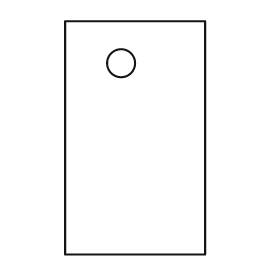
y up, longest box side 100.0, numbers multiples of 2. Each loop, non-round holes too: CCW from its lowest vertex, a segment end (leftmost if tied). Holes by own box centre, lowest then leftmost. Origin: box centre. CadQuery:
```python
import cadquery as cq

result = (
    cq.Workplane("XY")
    .moveTo(-30.0, -50.0)
    .lineTo(30.0, -50.0)
    .lineTo(30.0, 50.0)
    .lineTo(-30.0, 50.0)
    .close()
    .moveTo(-6.0, 32.0)
    .circle(6.0)
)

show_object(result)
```